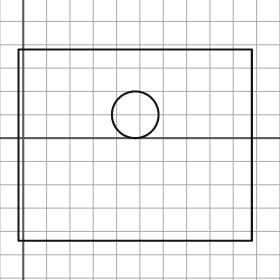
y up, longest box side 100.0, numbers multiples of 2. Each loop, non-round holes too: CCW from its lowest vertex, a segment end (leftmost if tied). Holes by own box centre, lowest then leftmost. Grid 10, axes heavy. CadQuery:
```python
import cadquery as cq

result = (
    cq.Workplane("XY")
    .moveTo(-2.0, -44.0)
    .lineTo(98.0, -44.0)
    .lineTo(98.0, 38.0)
    .lineTo(-2.0, 38.0)
    .close()
    .moveTo(48.0, 10.0)
    .circle(10.0)
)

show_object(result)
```